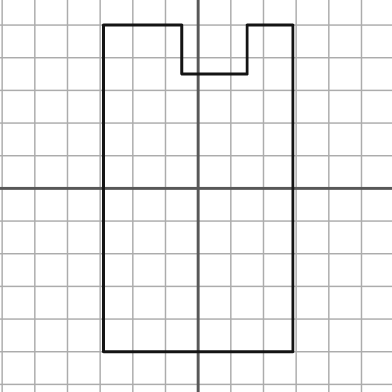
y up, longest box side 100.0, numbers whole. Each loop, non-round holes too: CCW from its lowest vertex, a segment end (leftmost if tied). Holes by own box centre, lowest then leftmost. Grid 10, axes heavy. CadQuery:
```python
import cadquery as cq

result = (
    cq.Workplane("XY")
    .moveTo(-29.0, -50.0)
    .lineTo(29.0, -50.0)
    .lineTo(29.0, 50.0)
    .lineTo(15.0, 50.0)
    .lineTo(15.0, 35.0)
    .lineTo(-5.0, 35.0)
    .lineTo(-5.0, 50.0)
    .lineTo(-29.0, 50.0)
    .close()
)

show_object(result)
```